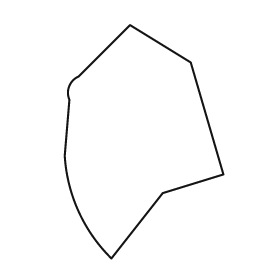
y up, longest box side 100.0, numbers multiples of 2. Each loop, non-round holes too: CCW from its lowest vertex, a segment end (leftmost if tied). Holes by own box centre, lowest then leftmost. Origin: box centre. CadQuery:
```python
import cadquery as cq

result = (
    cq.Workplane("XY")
    .moveTo(-14.0, -50.0)
    .lineTo(8.0, -22.0)
    .lineTo(34.0, -14.0)
    .lineTo(20.0, 34.0)
    .lineTo(-6.0, 50.0)
    .lineTo(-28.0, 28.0)
    .threePointArc((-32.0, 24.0), (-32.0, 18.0))
    .lineTo(-34.0, -6.0)
    .threePointArc((-28.0, -30.0), (-14.0, -50.0))
    .close()
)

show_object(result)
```